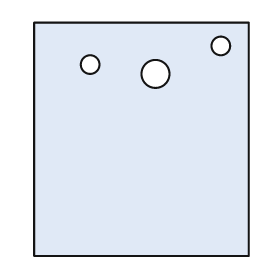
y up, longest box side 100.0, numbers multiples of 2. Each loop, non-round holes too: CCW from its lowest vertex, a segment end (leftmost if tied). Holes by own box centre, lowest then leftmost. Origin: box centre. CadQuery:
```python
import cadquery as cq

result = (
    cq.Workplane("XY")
    .moveTo(-46.0, -50.0)
    .lineTo(46.0, -50.0)
    .lineTo(46.0, 50.0)
    .lineTo(-46.0, 50.0)
    .close()
    .moveTo(6.0, 28.0)
    .circle(6.0)
    .moveTo(-22.0, 32.0)
    .circle(4.0)
    .moveTo(34.0, 40.0)
    .circle(4.0)
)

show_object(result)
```